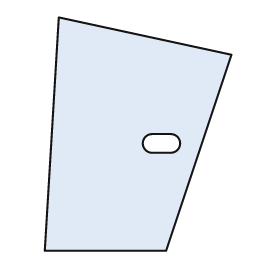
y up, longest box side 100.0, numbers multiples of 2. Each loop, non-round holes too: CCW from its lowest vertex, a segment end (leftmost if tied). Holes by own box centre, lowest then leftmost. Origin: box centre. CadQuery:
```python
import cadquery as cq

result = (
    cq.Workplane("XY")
    .moveTo(-40.0, -50.0)
    .lineTo(12.0, -50.0)
    .lineTo(40.0, 34.0)
    .lineTo(-34.0, 50.0)
    .close()
    .moveTo(6.0, -8.0)
    .lineTo(14.0, -8.0)
    .threePointArc((18.0, -4.0), (14.0, 0.0))
    .lineTo(6.0, 0.0)
    .threePointArc((2.0, -4.0), (6.0, -8.0))
    .close()
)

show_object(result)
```